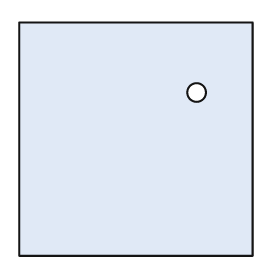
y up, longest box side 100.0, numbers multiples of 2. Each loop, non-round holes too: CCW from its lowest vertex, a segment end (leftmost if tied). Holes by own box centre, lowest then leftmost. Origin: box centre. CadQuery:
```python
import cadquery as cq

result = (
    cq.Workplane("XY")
    .moveTo(-50.0, -50.0)
    .lineTo(50.0, -50.0)
    .lineTo(50.0, 50.0)
    .lineTo(-50.0, 50.0)
    .close()
    .moveTo(26.0, 20.0)
    .circle(4.0)
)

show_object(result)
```